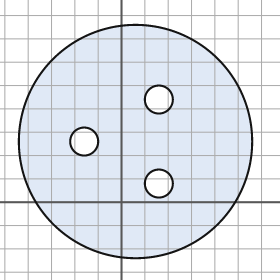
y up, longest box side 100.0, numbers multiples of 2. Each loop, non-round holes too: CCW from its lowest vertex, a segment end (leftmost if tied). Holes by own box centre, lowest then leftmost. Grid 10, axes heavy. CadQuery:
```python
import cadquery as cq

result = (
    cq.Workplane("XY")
    .moveTo(6.0, 26.0)
    .circle(50.0)
    .moveTo(16.0, 8.0)
    .circle(6.0)
    .moveTo(-16.0, 26.0)
    .circle(6.0)
    .moveTo(16.0, 44.0)
    .circle(6.0)
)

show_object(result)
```